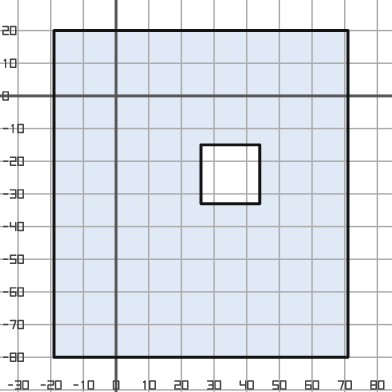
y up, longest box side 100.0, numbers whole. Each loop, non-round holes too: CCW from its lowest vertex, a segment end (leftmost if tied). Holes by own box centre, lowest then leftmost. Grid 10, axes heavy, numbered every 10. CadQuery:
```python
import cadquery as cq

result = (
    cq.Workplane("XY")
    .moveTo(-19.0, -80.0)
    .lineTo(71.0, -80.0)
    .lineTo(71.0, 20.0)
    .lineTo(-19.0, 20.0)
    .close()
    .moveTo(26.0, -33.0)
    .lineTo(44.0, -33.0)
    .lineTo(44.0, -15.0)
    .lineTo(26.0, -15.0)
    .close()
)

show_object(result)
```